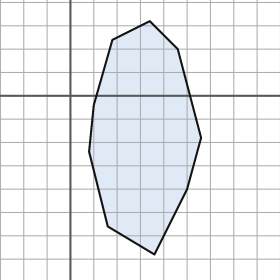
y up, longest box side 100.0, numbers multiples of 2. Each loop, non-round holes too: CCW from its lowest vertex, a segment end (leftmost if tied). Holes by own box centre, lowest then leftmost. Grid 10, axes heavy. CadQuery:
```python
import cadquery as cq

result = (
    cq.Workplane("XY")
    .moveTo(36.0, -68.0)
    .lineTo(50.0, -40.0)
    .lineTo(56.0, -18.0)
    .lineTo(46.0, 20.0)
    .lineTo(34.0, 32.0)
    .lineTo(18.0, 24.0)
    .lineTo(10.0, -4.0)
    .lineTo(8.0, -24.0)
    .lineTo(16.0, -56.0)
    .close()
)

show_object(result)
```